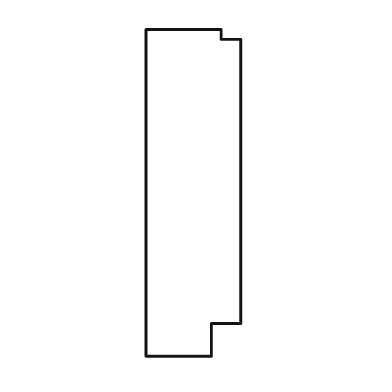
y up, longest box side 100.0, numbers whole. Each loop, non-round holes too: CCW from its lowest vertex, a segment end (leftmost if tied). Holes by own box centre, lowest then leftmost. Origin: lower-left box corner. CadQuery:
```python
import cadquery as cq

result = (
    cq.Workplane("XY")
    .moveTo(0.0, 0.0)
    .lineTo(20.0, 0.0)
    .lineTo(20.0, 10.0)
    .lineTo(29.0, 10.0)
    .lineTo(29.0, 97.0)
    .lineTo(23.0, 97.0)
    .lineTo(23.0, 100.0)
    .lineTo(0.0, 100.0)
    .close()
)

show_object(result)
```